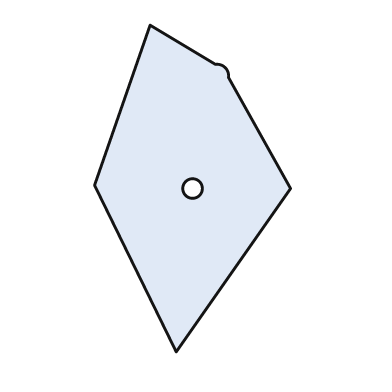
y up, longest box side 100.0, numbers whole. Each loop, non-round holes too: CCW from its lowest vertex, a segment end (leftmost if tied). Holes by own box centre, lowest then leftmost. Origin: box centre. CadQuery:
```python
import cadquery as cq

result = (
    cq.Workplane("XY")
    .moveTo(-5.0, -50.0)
    .lineTo(30.0, 0.0)
    .lineTo(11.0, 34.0)
    .threePointArc((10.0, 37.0), (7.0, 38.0))
    .lineTo(-13.0, 50.0)
    .lineTo(-30.0, 1.0)
    .close()
    .moveTo(0.0, 0.0)
    .circle(3.0)
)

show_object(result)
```